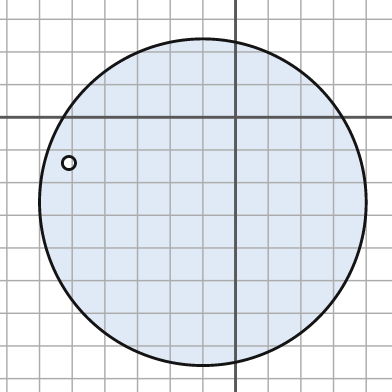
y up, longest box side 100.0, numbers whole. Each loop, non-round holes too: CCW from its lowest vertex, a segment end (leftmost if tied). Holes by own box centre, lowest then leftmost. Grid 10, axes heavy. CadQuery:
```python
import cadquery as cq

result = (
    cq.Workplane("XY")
    .moveTo(-10.0, -26.0)
    .circle(50.0)
    .moveTo(-51.0, -14.0)
    .circle(2.0)
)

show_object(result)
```